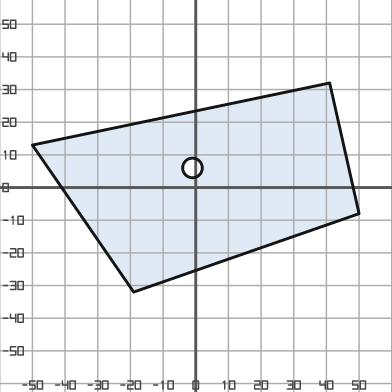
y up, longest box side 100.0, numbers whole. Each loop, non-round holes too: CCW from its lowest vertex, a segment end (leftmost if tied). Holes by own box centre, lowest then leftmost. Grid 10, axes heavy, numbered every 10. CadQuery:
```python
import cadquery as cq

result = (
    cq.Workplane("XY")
    .moveTo(-19.0, -32.0)
    .lineTo(50.0, -8.0)
    .lineTo(41.0, 32.0)
    .lineTo(-50.0, 13.0)
    .close()
    .moveTo(-1.0, 6.0)
    .circle(3.0)
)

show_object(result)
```